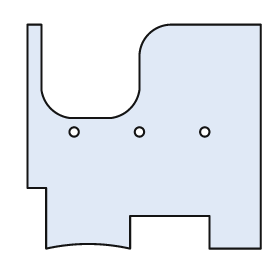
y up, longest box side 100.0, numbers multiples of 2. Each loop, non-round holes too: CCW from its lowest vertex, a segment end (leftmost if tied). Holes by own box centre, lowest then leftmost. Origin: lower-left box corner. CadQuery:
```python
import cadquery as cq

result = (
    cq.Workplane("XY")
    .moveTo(8.0, 0.0)
    .threePointArc((26.0, 2.0), (44.0, 0.0))
    .lineTo(44.0, 14.0)
    .lineTo(78.0, 14.0)
    .lineTo(78.0, 0.0)
    .lineTo(100.0, 0.0)
    .lineTo(100.0, 96.0)
    .lineTo(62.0, 96.0)
    .threePointArc((52.0, 92.0), (48.0, 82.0))
    .lineTo(48.0, 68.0)
    .threePointArc((44.0, 60.0), (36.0, 56.0))
    .lineTo(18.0, 56.0)
    .threePointArc((10.0, 60.0), (6.0, 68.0))
    .lineTo(6.0, 96.0)
    .lineTo(0.0, 96.0)
    .lineTo(0.0, 26.0)
    .lineTo(8.0, 26.0)
    .close()
    .moveTo(20.0, 50.0)
    .circle(2.0)
    .moveTo(48.0, 50.0)
    .circle(2.0)
    .moveTo(76.0, 50.0)
    .circle(2.0)
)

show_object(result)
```